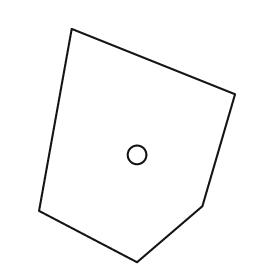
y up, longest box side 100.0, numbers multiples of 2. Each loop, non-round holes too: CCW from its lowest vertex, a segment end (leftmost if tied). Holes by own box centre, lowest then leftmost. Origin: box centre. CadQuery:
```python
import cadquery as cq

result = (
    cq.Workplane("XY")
    .moveTo(0.0, -50.0)
    .lineTo(28.0, -26.0)
    .lineTo(42.0, 22.0)
    .lineTo(-28.0, 50.0)
    .lineTo(-42.0, -28.0)
    .close()
    .moveTo(0.0, -4.0)
    .circle(4.0)
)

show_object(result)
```